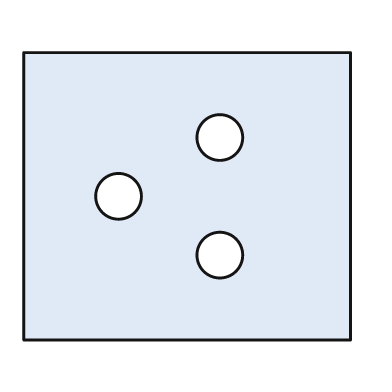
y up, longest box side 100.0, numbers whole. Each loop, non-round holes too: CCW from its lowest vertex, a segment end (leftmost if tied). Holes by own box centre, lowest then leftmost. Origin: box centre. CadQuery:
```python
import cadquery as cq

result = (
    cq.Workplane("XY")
    .moveTo(-50.0, -44.0)
    .lineTo(50.0, -44.0)
    .lineTo(50.0, 44.0)
    .lineTo(-50.0, 44.0)
    .close()
    .moveTo(10.0, -18.0)
    .circle(7.0)
    .moveTo(-21.0, 0.0)
    .circle(7.0)
    .moveTo(10.0, 18.0)
    .circle(7.0)
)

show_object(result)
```